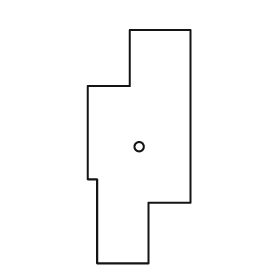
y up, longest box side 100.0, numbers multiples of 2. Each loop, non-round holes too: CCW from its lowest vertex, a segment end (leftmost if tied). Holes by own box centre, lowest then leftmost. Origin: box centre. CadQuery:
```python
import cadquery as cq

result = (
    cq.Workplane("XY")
    .moveTo(-18.0, -50.0)
    .lineTo(4.0, -50.0)
    .lineTo(4.0, -24.0)
    .lineTo(22.0, -24.0)
    .lineTo(22.0, 50.0)
    .lineTo(-4.0, 50.0)
    .lineTo(-4.0, 26.0)
    .lineTo(-22.0, 26.0)
    .lineTo(-22.0, -14.0)
    .lineTo(-18.0, -14.0)
    .close()
    .moveTo(0.0, 0.0)
    .circle(2.0)
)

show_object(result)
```